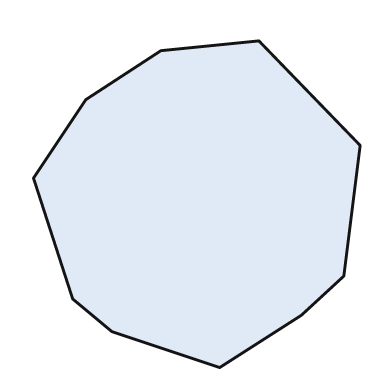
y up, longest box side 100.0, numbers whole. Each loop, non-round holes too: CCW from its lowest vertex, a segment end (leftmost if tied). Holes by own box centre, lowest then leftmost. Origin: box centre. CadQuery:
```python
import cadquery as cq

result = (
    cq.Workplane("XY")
    .moveTo(7.0, -50.0)
    .lineTo(32.0, -34.0)
    .lineTo(45.0, -22.0)
    .lineTo(50.0, 18.0)
    .lineTo(19.0, 50.0)
    .lineTo(-11.0, 47.0)
    .lineTo(-34.0, 32.0)
    .lineTo(-50.0, 8.0)
    .lineTo(-38.0, -29.0)
    .lineTo(-26.0, -39.0)
    .close()
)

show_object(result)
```